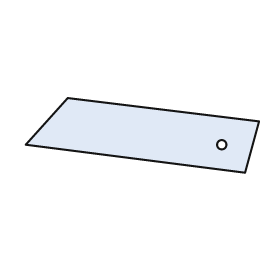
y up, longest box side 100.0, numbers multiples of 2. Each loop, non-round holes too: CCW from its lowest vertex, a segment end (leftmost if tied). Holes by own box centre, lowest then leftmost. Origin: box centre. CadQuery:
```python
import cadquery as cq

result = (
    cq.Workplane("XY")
    .moveTo(44.0, -16.0)
    .lineTo(50.0, 6.0)
    .lineTo(-32.0, 16.0)
    .lineTo(-50.0, -4.0)
    .close()
    .moveTo(34.0, -4.0)
    .circle(2.0)
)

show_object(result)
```